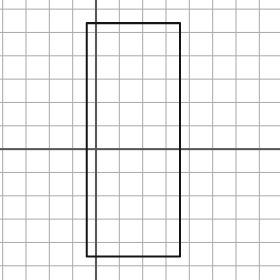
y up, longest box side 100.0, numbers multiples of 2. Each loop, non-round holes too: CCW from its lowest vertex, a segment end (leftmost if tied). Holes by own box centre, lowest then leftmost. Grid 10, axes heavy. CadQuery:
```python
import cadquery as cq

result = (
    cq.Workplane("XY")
    .moveTo(-4.0, -46.0)
    .lineTo(36.0, -46.0)
    .lineTo(36.0, 54.0)
    .lineTo(-4.0, 54.0)
    .close()
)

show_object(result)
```